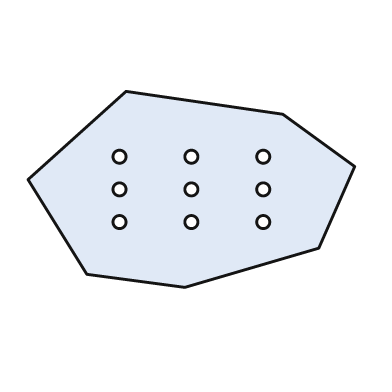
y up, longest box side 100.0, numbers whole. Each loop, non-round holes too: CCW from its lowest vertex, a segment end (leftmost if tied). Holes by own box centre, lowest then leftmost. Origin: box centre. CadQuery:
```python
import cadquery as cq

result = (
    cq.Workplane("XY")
    .moveTo(-2.0, -30.0)
    .lineTo(39.0, -18.0)
    .lineTo(50.0, 7.0)
    .lineTo(28.0, 23.0)
    .lineTo(-20.0, 30.0)
    .lineTo(-50.0, 3.0)
    .lineTo(-32.0, -26.0)
    .close()
    .moveTo(-22.0, -10.0)
    .circle(2.0)
    .moveTo(0.0, -10.0)
    .circle(2.0)
    .moveTo(22.0, -10.0)
    .circle(2.0)
    .moveTo(-22.0, 0.0)
    .circle(2.0)
    .moveTo(0.0, 0.0)
    .circle(2.0)
    .moveTo(22.0, 0.0)
    .circle(2.0)
    .moveTo(-22.0, 10.0)
    .circle(2.0)
    .moveTo(0.0, 10.0)
    .circle(2.0)
    .moveTo(22.0, 10.0)
    .circle(2.0)
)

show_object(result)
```